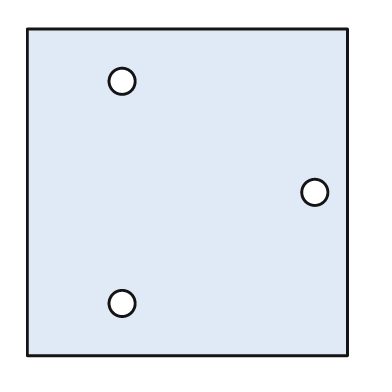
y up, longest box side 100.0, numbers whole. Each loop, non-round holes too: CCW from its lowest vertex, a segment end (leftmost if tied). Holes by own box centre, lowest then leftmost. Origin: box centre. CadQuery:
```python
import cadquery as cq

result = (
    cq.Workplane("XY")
    .moveTo(-49.0, -50.0)
    .lineTo(49.0, -50.0)
    .lineTo(49.0, 50.0)
    .lineTo(-49.0, 50.0)
    .close()
    .moveTo(-20.0, -34.0)
    .circle(4.0)
    .moveTo(39.0, 0.0)
    .circle(4.0)
    .moveTo(-20.0, 34.0)
    .circle(4.0)
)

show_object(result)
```